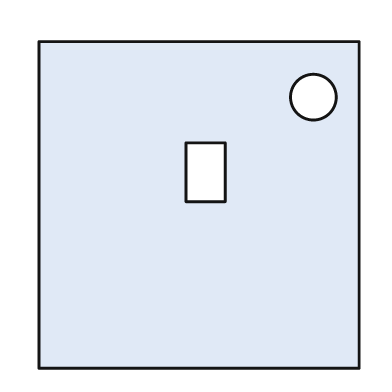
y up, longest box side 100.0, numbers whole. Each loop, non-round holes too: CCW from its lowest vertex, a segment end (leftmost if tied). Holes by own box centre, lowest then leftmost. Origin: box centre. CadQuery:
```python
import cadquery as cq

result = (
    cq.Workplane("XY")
    .moveTo(-49.0, -50.0)
    .lineTo(49.0, -50.0)
    .lineTo(49.0, 50.0)
    .lineTo(-49.0, 50.0)
    .close()
    .moveTo(-4.0, 1.0)
    .lineTo(8.0, 1.0)
    .lineTo(8.0, 19.0)
    .lineTo(-4.0, 19.0)
    .close()
    .moveTo(35.0, 33.0)
    .circle(7.0)
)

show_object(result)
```